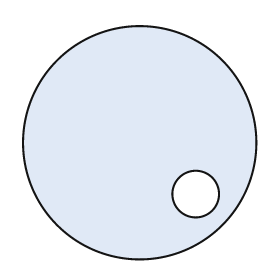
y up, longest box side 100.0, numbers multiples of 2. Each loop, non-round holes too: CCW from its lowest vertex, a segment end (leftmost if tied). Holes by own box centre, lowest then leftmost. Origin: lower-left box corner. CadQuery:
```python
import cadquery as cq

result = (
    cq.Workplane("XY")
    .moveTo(50.0, 50.0)
    .circle(50.0)
    .moveTo(74.0, 28.0)
    .circle(10.0)
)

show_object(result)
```